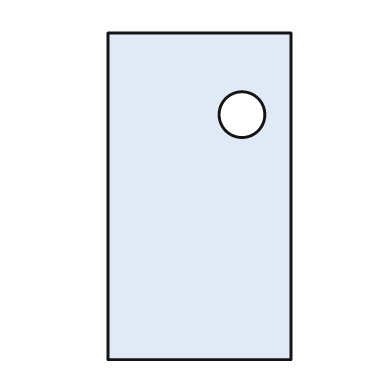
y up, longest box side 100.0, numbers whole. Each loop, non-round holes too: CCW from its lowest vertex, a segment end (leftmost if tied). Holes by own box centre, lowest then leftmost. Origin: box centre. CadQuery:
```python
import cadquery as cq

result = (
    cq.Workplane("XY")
    .moveTo(-28.0, -50.0)
    .lineTo(28.0, -50.0)
    .lineTo(28.0, 50.0)
    .lineTo(-28.0, 50.0)
    .close()
    .moveTo(13.0, 25.0)
    .circle(7.0)
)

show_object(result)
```